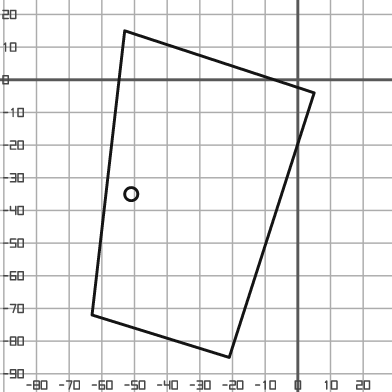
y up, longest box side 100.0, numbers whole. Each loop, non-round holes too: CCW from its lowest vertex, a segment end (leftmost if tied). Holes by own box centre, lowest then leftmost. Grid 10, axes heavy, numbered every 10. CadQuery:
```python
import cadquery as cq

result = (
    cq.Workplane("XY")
    .moveTo(-21.0, -85.0)
    .lineTo(5.0, -4.0)
    .lineTo(-53.0, 15.0)
    .lineTo(-63.0, -72.0)
    .close()
    .moveTo(-51.0, -35.0)
    .circle(2.0)
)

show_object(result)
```